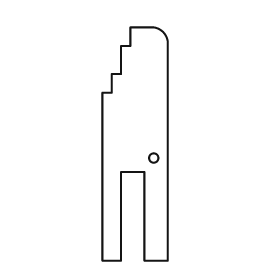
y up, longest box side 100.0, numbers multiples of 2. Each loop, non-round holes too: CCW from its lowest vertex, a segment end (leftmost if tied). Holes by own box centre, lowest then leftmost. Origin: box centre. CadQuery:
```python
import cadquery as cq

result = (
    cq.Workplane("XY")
    .moveTo(-14.0, -50.0)
    .lineTo(-6.0, -50.0)
    .lineTo(-6.0, -12.0)
    .lineTo(4.0, -12.0)
    .lineTo(4.0, -50.0)
    .lineTo(14.0, -50.0)
    .lineTo(14.0, 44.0)
    .threePointArc((12.0, 48.0), (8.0, 50.0))
    .lineTo(-2.0, 50.0)
    .lineTo(-2.0, 42.0)
    .lineTo(-6.0, 42.0)
    .lineTo(-6.0, 30.0)
    .lineTo(-10.0, 30.0)
    .lineTo(-10.0, 22.0)
    .lineTo(-14.0, 22.0)
    .close()
    .moveTo(8.0, -6.0)
    .circle(2.0)
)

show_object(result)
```